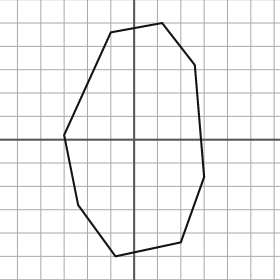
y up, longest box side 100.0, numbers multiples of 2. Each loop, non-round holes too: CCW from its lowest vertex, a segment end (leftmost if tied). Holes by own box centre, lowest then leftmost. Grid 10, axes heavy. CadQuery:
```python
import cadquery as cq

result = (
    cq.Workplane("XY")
    .moveTo(-8.0, -50.0)
    .lineTo(20.0, -44.0)
    .lineTo(30.0, -16.0)
    .lineTo(26.0, 32.0)
    .lineTo(12.0, 50.0)
    .lineTo(-10.0, 46.0)
    .lineTo(-30.0, 2.0)
    .lineTo(-24.0, -28.0)
    .close()
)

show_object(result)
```